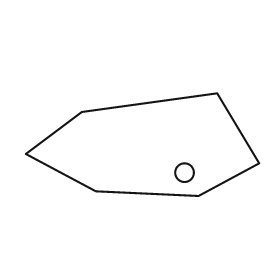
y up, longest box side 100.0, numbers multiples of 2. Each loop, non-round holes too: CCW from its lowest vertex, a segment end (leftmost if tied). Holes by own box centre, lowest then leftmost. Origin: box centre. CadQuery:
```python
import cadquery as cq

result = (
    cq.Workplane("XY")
    .moveTo(24.0, -22.0)
    .lineTo(50.0, -8.0)
    .lineTo(32.0, 22.0)
    .lineTo(-26.0, 14.0)
    .lineTo(-50.0, -4.0)
    .lineTo(-20.0, -20.0)
    .close()
    .moveTo(18.0, -12.0)
    .circle(4.0)
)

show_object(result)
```